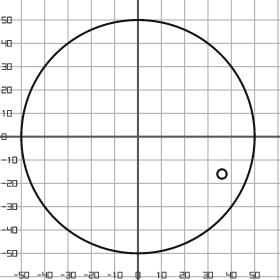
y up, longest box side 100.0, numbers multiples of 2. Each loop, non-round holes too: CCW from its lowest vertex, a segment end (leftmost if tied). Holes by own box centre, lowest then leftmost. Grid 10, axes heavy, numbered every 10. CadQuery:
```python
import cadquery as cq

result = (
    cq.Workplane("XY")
    .moveTo(0.0, 0.0)
    .circle(50.0)
    .moveTo(36.0, -16.0)
    .circle(2.0)
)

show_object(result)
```